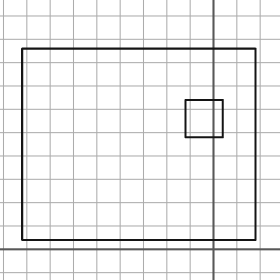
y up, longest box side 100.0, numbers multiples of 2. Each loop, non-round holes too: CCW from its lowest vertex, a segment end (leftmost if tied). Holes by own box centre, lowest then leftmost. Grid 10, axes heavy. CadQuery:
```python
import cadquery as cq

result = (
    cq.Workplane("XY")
    .moveTo(-82.0, 4.0)
    .lineTo(18.0, 4.0)
    .lineTo(18.0, 86.0)
    .lineTo(-82.0, 86.0)
    .close()
    .moveTo(-12.0, 48.0)
    .lineTo(4.0, 48.0)
    .lineTo(4.0, 64.0)
    .lineTo(-12.0, 64.0)
    .close()
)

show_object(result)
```